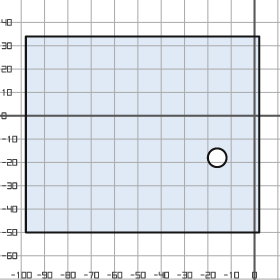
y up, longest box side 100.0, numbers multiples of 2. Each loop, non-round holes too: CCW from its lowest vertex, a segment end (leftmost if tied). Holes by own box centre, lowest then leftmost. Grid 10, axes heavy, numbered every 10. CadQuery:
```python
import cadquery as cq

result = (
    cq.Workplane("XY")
    .moveTo(-98.0, -50.0)
    .lineTo(2.0, -50.0)
    .lineTo(2.0, 34.0)
    .lineTo(-98.0, 34.0)
    .close()
    .moveTo(-16.0, -18.0)
    .circle(4.0)
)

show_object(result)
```